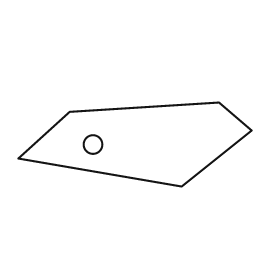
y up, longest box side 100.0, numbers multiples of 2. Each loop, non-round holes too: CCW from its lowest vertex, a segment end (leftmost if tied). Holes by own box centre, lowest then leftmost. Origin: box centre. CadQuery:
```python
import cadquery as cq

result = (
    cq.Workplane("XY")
    .moveTo(20.0, -18.0)
    .lineTo(50.0, 6.0)
    .lineTo(36.0, 18.0)
    .lineTo(-28.0, 14.0)
    .lineTo(-50.0, -6.0)
    .close()
    .moveTo(-18.0, 0.0)
    .circle(4.0)
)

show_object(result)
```